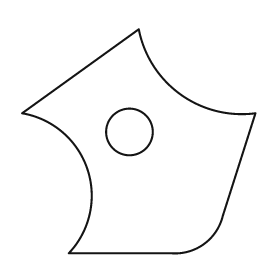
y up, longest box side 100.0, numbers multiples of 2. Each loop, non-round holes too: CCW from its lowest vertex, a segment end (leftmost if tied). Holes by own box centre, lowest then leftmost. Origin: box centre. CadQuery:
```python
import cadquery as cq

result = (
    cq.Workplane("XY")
    .moveTo(-30.0, -48.0)
    .lineTo(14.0, -48.0)
    .threePointArc((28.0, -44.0), (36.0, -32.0))
    .lineTo(50.0, 12.0)
    .threePointArc((18.0, 20.0), (0.0, 48.0))
    .lineTo(-50.0, 12.0)
    .threePointArc((-22.0, -12.0), (-30.0, -48.0))
    .close()
    .moveTo(-4.0, 4.0)
    .circle(10.0)
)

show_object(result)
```